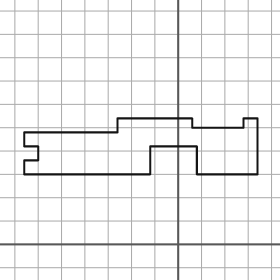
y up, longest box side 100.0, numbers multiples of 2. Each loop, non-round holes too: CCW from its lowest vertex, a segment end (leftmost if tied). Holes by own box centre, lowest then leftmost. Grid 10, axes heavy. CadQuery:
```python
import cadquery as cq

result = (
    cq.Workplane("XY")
    .moveTo(-66.0, 30.0)
    .lineTo(-12.0, 30.0)
    .lineTo(-12.0, 42.0)
    .lineTo(8.0, 42.0)
    .lineTo(8.0, 30.0)
    .lineTo(34.0, 30.0)
    .lineTo(34.0, 54.0)
    .lineTo(28.0, 54.0)
    .lineTo(28.0, 50.0)
    .lineTo(6.0, 50.0)
    .lineTo(6.0, 54.0)
    .lineTo(-26.0, 54.0)
    .lineTo(-26.0, 48.0)
    .lineTo(-66.0, 48.0)
    .lineTo(-66.0, 42.0)
    .lineTo(-60.0, 42.0)
    .lineTo(-60.0, 36.0)
    .lineTo(-66.0, 36.0)
    .close()
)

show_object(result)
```